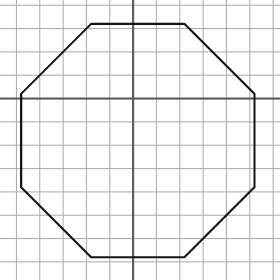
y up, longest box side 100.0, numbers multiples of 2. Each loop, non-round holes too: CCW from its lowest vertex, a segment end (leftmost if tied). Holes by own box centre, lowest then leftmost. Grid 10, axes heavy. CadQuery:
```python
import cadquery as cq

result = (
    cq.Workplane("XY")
    .moveTo(-18.0, -68.0)
    .lineTo(22.0, -68.0)
    .lineTo(52.0, -38.0)
    .lineTo(52.0, 2.0)
    .lineTo(22.0, 32.0)
    .lineTo(-18.0, 32.0)
    .lineTo(-48.0, 2.0)
    .lineTo(-48.0, -38.0)
    .close()
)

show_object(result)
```